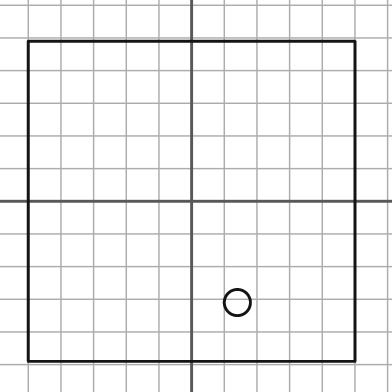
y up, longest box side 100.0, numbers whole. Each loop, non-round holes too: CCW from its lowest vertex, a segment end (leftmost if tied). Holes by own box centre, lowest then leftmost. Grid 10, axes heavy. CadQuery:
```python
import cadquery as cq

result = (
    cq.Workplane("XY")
    .moveTo(-50.0, -49.0)
    .lineTo(50.0, -49.0)
    .lineTo(50.0, 49.0)
    .lineTo(-50.0, 49.0)
    .close()
    .moveTo(14.0, -31.0)
    .circle(4.0)
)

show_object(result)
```